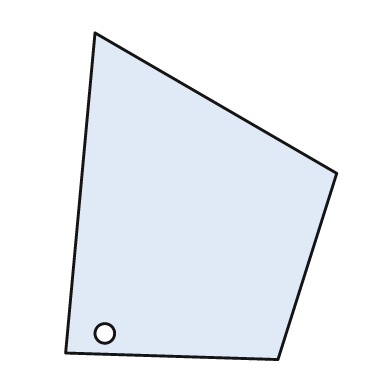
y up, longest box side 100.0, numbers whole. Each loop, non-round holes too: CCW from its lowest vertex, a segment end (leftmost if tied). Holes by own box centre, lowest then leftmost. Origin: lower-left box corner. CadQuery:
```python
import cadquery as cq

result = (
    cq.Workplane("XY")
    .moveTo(65.0, 0.0)
    .lineTo(83.0, 57.0)
    .lineTo(9.0, 100.0)
    .lineTo(0.0, 2.0)
    .close()
    .moveTo(12.0, 8.0)
    .circle(3.0)
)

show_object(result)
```